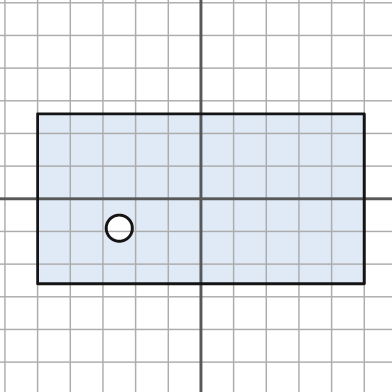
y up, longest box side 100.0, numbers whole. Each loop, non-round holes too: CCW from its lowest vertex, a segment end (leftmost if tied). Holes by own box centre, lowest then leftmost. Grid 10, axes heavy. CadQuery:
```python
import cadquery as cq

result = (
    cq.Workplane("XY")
    .moveTo(-50.0, -26.0)
    .lineTo(50.0, -26.0)
    .lineTo(50.0, 26.0)
    .lineTo(-50.0, 26.0)
    .close()
    .moveTo(-25.0, -9.0)
    .circle(4.0)
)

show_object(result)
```